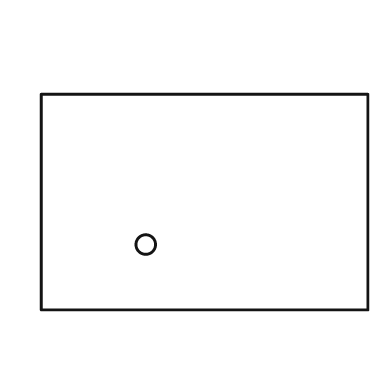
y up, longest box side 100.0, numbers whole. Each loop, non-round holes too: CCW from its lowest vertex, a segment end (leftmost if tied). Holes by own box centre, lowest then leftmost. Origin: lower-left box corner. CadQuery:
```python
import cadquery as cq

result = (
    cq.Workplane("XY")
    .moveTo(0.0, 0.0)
    .lineTo(100.0, 0.0)
    .lineTo(100.0, 66.0)
    .lineTo(0.0, 66.0)
    .close()
    .moveTo(32.0, 20.0)
    .circle(3.0)
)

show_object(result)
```